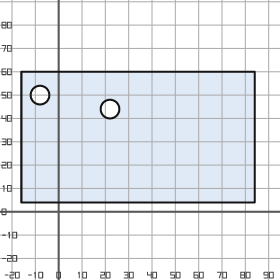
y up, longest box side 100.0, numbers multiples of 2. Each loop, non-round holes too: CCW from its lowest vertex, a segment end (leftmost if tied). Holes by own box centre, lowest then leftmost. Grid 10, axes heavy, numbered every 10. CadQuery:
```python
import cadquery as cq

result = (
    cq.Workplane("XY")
    .moveTo(-16.0, 4.0)
    .lineTo(84.0, 4.0)
    .lineTo(84.0, 60.0)
    .lineTo(-16.0, 60.0)
    .close()
    .moveTo(22.0, 44.0)
    .circle(4.0)
    .moveTo(-8.0, 50.0)
    .circle(4.0)
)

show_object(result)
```